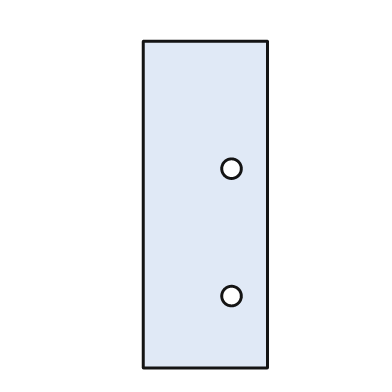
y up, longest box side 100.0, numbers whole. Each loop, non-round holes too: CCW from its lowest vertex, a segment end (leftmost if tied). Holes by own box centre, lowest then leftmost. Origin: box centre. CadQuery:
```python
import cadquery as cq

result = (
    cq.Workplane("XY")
    .moveTo(-19.0, -50.0)
    .lineTo(19.0, -50.0)
    .lineTo(19.0, 50.0)
    .lineTo(-19.0, 50.0)
    .close()
    .moveTo(8.0, -28.0)
    .circle(3.0)
    .moveTo(8.0, 11.0)
    .circle(3.0)
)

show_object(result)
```